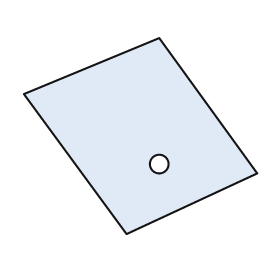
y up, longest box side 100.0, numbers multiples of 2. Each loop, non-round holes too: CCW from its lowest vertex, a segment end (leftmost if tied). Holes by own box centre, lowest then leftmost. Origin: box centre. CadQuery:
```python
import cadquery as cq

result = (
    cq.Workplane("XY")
    .moveTo(-6.0, -42.0)
    .lineTo(50.0, -16.0)
    .lineTo(8.0, 42.0)
    .lineTo(-50.0, 18.0)
    .close()
    .moveTo(8.0, -12.0)
    .circle(4.0)
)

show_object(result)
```